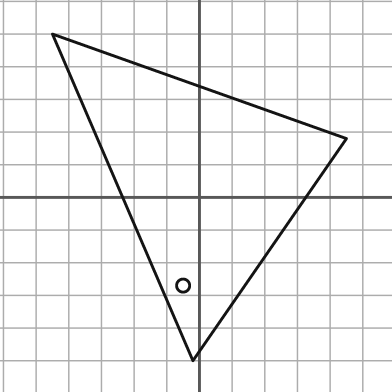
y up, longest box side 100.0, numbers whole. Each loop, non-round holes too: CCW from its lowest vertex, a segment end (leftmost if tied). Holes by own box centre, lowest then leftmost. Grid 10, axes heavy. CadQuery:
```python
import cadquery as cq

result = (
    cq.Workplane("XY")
    .moveTo(-2.0, -50.0)
    .lineTo(45.0, 18.0)
    .lineTo(-45.0, 50.0)
    .close()
    .moveTo(-5.0, -27.0)
    .circle(2.0)
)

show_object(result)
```